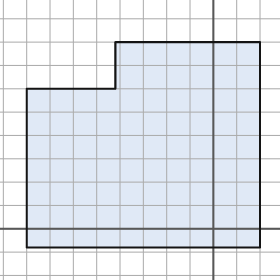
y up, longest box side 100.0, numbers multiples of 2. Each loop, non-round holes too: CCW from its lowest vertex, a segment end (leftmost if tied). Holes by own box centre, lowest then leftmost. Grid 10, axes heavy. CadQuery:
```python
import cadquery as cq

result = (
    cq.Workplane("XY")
    .moveTo(-80.0, -8.0)
    .lineTo(20.0, -8.0)
    .lineTo(20.0, 80.0)
    .lineTo(-42.0, 80.0)
    .lineTo(-42.0, 60.0)
    .lineTo(-80.0, 60.0)
    .close()
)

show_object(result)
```